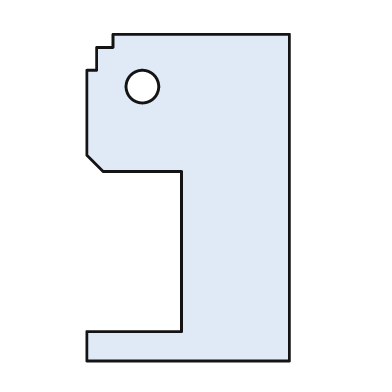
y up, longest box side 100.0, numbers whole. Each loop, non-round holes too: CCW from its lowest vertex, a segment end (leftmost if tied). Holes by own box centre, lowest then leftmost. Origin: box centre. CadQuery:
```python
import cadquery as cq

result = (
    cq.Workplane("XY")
    .moveTo(-31.0, -50.0)
    .lineTo(31.0, -50.0)
    .lineTo(31.0, 50.0)
    .lineTo(-23.0, 50.0)
    .lineTo(-23.0, 46.0)
    .lineTo(-28.0, 46.0)
    .lineTo(-28.0, 39.0)
    .lineTo(-31.0, 39.0)
    .lineTo(-31.0, 13.0)
    .lineTo(-26.0, 8.0)
    .lineTo(-2.0, 8.0)
    .lineTo(-2.0, -41.0)
    .lineTo(-31.0, -41.0)
    .close()
    .moveTo(-14.0, 34.0)
    .circle(5.0)
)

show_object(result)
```